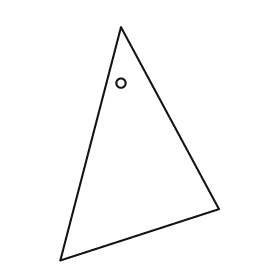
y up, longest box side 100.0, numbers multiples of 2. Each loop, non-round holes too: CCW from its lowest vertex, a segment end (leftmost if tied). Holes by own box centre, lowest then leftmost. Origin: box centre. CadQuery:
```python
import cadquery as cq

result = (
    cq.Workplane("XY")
    .moveTo(-34.0, -50.0)
    .lineTo(34.0, -28.0)
    .lineTo(-8.0, 50.0)
    .close()
    .moveTo(-8.0, 26.0)
    .circle(2.0)
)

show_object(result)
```